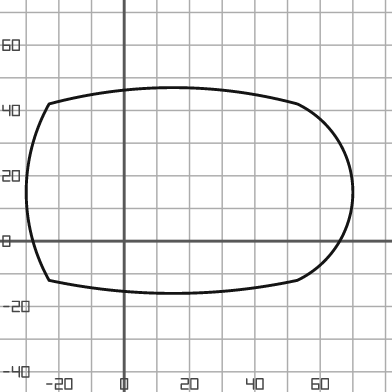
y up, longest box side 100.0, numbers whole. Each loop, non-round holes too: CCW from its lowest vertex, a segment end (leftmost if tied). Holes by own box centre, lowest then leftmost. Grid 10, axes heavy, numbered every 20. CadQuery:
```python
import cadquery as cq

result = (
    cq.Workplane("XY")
    .moveTo(-23.0, -12.0)
    .threePointArc((15.0, -16.0), (53.0, -12.0))
    .threePointArc((70.0, 15.0), (53.0, 42.0))
    .threePointArc((15.0, 47.0), (-23.0, 42.0))
    .threePointArc((-30.0, 15.0), (-23.0, -12.0))
    .close()
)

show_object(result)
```